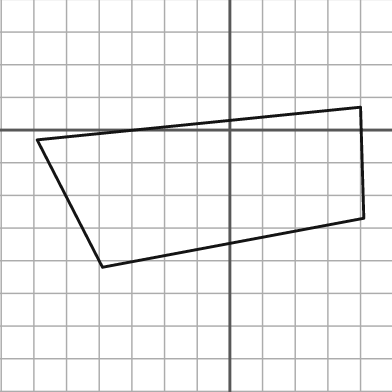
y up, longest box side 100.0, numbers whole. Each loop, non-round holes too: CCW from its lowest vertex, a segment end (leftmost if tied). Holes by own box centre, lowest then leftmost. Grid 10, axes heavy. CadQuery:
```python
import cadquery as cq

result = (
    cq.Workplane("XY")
    .moveTo(-39.0, -42.0)
    .lineTo(41.0, -27.0)
    .lineTo(40.0, 7.0)
    .lineTo(-59.0, -3.0)
    .close()
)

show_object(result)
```